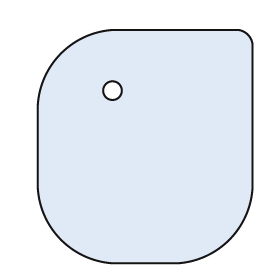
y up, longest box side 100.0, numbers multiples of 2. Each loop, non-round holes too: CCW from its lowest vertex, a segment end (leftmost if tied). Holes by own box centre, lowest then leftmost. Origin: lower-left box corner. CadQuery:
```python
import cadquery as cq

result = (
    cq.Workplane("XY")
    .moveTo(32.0, 0.0)
    .lineTo(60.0, 0.0)
    .threePointArc((82.0, 10.0), (92.0, 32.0))
    .lineTo(92.0, 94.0)
    .threePointArc((90.0, 98.0), (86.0, 100.0))
    .lineTo(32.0, 100.0)
    .threePointArc((10.0, 90.0), (0.0, 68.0))
    .lineTo(0.0, 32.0)
    .threePointArc((10.0, 10.0), (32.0, 0.0))
    .close()
    .moveTo(32.0, 74.0)
    .circle(4.0)
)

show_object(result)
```